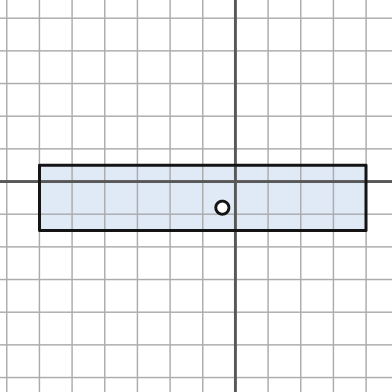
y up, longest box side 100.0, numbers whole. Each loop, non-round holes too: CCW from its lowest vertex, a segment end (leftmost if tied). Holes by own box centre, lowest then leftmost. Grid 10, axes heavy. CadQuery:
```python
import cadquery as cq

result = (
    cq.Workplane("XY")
    .moveTo(-60.0, -15.0)
    .lineTo(40.0, -15.0)
    .lineTo(40.0, 5.0)
    .lineTo(-60.0, 5.0)
    .close()
    .moveTo(-4.0, -8.0)
    .circle(2.0)
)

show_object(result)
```